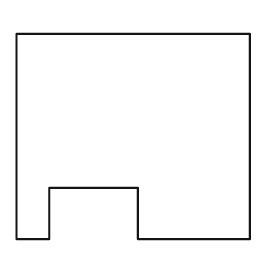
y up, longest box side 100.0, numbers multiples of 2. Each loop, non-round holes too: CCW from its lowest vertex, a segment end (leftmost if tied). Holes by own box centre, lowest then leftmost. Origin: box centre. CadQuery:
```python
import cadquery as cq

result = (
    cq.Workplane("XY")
    .moveTo(-50.0, -44.0)
    .lineTo(-36.0, -44.0)
    .lineTo(-36.0, -22.0)
    .lineTo(2.0, -22.0)
    .lineTo(2.0, -44.0)
    .lineTo(50.0, -44.0)
    .lineTo(50.0, 44.0)
    .lineTo(-50.0, 44.0)
    .close()
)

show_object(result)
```